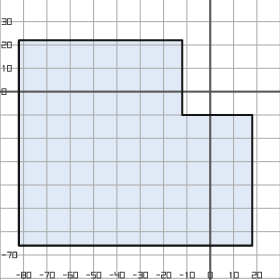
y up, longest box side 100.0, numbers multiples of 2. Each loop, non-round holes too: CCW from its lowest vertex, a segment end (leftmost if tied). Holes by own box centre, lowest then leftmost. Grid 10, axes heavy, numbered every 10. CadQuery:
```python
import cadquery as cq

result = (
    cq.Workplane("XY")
    .moveTo(-82.0, -66.0)
    .lineTo(18.0, -66.0)
    .lineTo(18.0, -10.0)
    .lineTo(-12.0, -10.0)
    .lineTo(-12.0, 22.0)
    .lineTo(-82.0, 22.0)
    .close()
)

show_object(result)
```